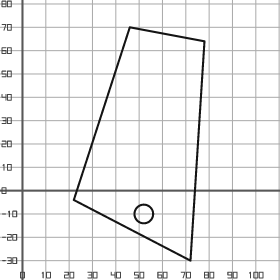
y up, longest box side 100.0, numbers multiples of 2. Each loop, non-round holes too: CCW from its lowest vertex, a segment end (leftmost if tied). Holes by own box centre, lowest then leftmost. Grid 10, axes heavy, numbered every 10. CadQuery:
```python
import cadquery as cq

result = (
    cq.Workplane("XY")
    .moveTo(72.0, -30.0)
    .lineTo(78.0, 64.0)
    .lineTo(46.0, 70.0)
    .lineTo(22.0, -4.0)
    .close()
    .moveTo(52.0, -10.0)
    .circle(4.0)
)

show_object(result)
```